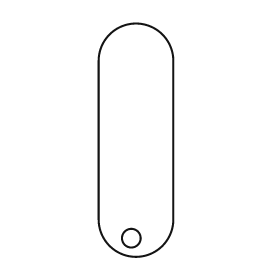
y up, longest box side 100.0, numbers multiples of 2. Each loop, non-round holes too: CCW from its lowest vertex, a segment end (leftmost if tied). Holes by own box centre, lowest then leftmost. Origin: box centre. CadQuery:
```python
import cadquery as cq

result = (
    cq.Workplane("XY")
    .moveTo(-16.0, -34.0)
    .threePointArc((0.0, -50.0), (16.0, -34.0))
    .lineTo(16.0, 34.0)
    .threePointArc((0.0, 50.0), (-16.0, 34.0))
    .close()
    .moveTo(-2.0, -42.0)
    .circle(4.0)
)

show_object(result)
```